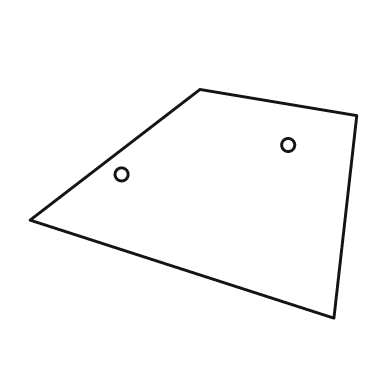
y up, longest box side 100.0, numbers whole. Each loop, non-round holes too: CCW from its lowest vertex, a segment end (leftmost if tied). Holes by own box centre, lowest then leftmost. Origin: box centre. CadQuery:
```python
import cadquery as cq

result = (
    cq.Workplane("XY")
    .moveTo(43.0, -35.0)
    .lineTo(50.0, 27.0)
    .lineTo(2.0, 35.0)
    .lineTo(-50.0, -5.0)
    .close()
    .moveTo(-22.0, 9.0)
    .circle(2.0)
    .moveTo(29.0, 18.0)
    .circle(2.0)
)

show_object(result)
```